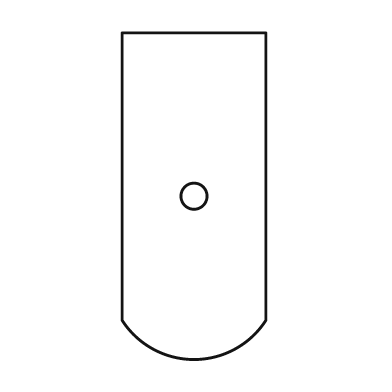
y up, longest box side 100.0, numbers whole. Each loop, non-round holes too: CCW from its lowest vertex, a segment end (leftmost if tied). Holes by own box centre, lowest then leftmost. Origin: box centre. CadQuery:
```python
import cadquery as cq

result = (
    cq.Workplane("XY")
    .moveTo(-22.0, -38.0)
    .threePointArc((0.0, -50.0), (22.0, -38.0))
    .lineTo(22.0, 50.0)
    .lineTo(-22.0, 50.0)
    .close()
    .moveTo(0.0, 0.0)
    .circle(4.0)
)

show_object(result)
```